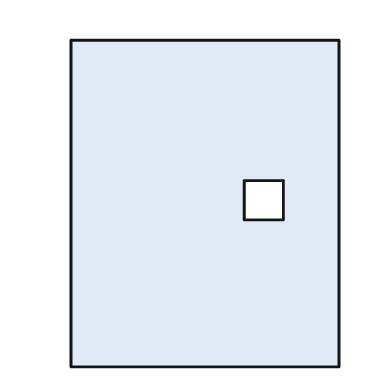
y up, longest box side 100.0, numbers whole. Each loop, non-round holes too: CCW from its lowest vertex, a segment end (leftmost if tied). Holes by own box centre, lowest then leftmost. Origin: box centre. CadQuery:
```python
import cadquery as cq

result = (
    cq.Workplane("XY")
    .moveTo(-41.0, -50.0)
    .lineTo(41.0, -50.0)
    .lineTo(41.0, 50.0)
    .lineTo(-41.0, 50.0)
    .close()
    .moveTo(12.0, -5.0)
    .lineTo(24.0, -5.0)
    .lineTo(24.0, 7.0)
    .lineTo(12.0, 7.0)
    .close()
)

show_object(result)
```